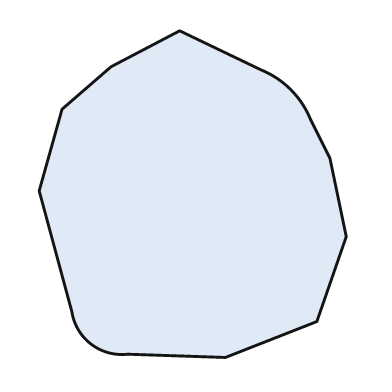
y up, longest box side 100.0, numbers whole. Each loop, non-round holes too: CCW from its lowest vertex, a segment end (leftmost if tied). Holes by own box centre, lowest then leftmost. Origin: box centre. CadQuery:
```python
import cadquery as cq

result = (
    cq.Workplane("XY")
    .moveTo(10.0, -50.0)
    .lineTo(38.0, -39.0)
    .lineTo(47.0, -13.0)
    .lineTo(42.0, 11.0)
    .lineTo(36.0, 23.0)
    .threePointArc((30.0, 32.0), (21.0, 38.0))
    .lineTo(-4.0, 50.0)
    .lineTo(-25.0, 39.0)
    .lineTo(-40.0, 26.0)
    .lineTo(-47.0, 1.0)
    .lineTo(-37.0, -36.0)
    .threePointArc((-31.0, -46.0), (-20.0, -49.0))
    .close()
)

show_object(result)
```